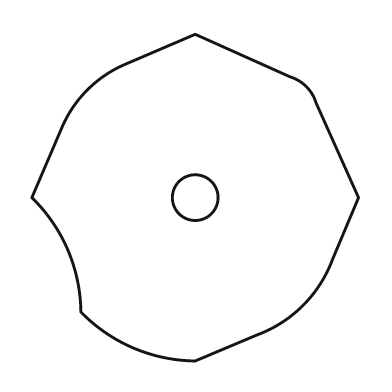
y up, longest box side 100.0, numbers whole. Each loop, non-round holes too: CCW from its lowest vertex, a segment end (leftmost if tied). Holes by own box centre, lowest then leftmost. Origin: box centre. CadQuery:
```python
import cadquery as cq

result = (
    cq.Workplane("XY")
    .moveTo(0.0, -50.0)
    .lineTo(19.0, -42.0)
    .threePointArc((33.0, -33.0), (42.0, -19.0))
    .lineTo(50.0, 0.0)
    .lineTo(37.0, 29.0)
    .threePointArc((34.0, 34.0), (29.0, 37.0))
    .lineTo(0.0, 50.0)
    .lineTo(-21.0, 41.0)
    .threePointArc((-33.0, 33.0), (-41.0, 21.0))
    .lineTo(-50.0, 0.0)
    .threePointArc((-39.0, -16.0), (-35.0, -35.0))
    .threePointArc((-19.0, -46.0), (0.0, -50.0))
    .close()
    .moveTo(0.0, 0.0)
    .circle(7.0)
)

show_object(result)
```